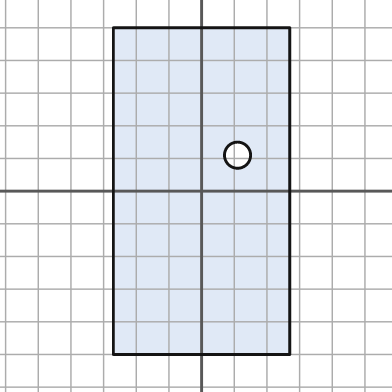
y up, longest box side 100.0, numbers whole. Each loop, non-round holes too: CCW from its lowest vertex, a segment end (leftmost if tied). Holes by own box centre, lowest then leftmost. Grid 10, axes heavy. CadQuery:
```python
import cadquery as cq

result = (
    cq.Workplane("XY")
    .moveTo(-27.0, -50.0)
    .lineTo(27.0, -50.0)
    .lineTo(27.0, 50.0)
    .lineTo(-27.0, 50.0)
    .close()
    .moveTo(11.0, 11.0)
    .circle(4.0)
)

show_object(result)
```